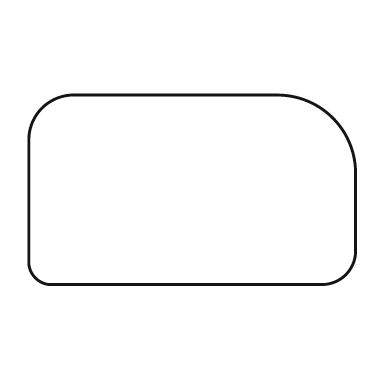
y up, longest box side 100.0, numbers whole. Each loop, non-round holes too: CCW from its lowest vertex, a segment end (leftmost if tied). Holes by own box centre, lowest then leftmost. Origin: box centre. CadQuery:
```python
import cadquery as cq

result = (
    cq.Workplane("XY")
    .moveTo(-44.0, -29.0)
    .lineTo(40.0, -29.0)
    .threePointArc((47.0, -26.0), (50.0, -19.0))
    .lineTo(50.0, 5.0)
    .threePointArc((43.0, 22.0), (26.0, 29.0))
    .lineTo(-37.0, 29.0)
    .threePointArc((-46.0, 25.0), (-50.0, 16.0))
    .lineTo(-50.0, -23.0)
    .threePointArc((-48.0, -27.0), (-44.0, -29.0))
    .close()
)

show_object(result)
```